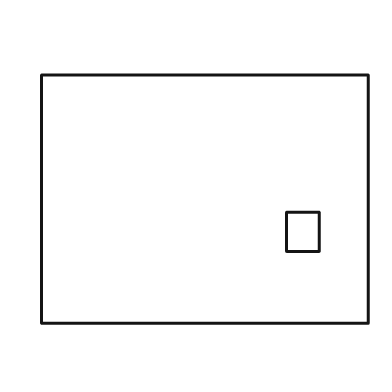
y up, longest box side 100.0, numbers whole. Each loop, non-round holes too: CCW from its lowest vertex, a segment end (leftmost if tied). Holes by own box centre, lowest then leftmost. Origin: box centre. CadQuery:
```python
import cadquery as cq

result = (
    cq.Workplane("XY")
    .moveTo(-50.0, -38.0)
    .lineTo(50.0, -38.0)
    .lineTo(50.0, 38.0)
    .lineTo(-50.0, 38.0)
    .close()
    .moveTo(25.0, -16.0)
    .lineTo(35.0, -16.0)
    .lineTo(35.0, -4.0)
    .lineTo(25.0, -4.0)
    .close()
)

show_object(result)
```